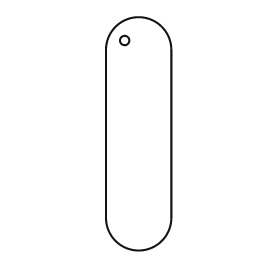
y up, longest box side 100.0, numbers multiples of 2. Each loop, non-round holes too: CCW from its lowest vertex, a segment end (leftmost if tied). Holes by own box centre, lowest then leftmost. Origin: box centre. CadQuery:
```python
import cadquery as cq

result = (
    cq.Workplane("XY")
    .moveTo(-14.0, -36.0)
    .threePointArc((0.0, -50.0), (14.0, -36.0))
    .lineTo(14.0, 36.0)
    .threePointArc((0.0, 50.0), (-14.0, 36.0))
    .close()
    .moveTo(-6.0, 40.0)
    .circle(2.0)
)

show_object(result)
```